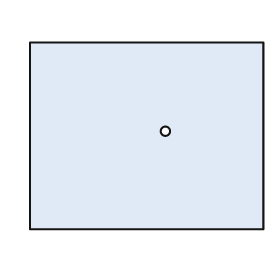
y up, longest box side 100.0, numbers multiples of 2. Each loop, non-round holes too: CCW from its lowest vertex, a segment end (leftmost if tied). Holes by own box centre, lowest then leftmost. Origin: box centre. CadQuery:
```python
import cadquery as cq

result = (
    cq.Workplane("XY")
    .moveTo(-50.0, -40.0)
    .lineTo(50.0, -40.0)
    .lineTo(50.0, 40.0)
    .lineTo(-50.0, 40.0)
    .close()
    .moveTo(8.0, 2.0)
    .circle(2.0)
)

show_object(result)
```